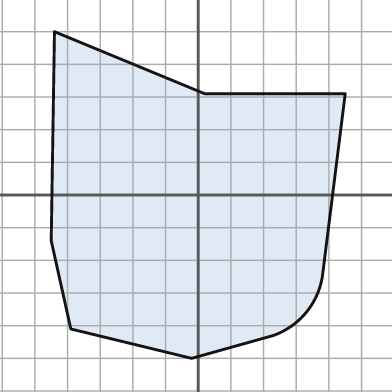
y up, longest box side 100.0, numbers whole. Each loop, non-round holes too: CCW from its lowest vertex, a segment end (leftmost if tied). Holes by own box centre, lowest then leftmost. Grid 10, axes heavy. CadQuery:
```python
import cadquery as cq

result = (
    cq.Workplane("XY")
    .moveTo(-2.0, -50.0)
    .lineTo(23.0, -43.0)
    .threePointArc((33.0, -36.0), (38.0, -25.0))
    .lineTo(45.0, 31.0)
    .lineTo(2.0, 31.0)
    .lineTo(-44.0, 50.0)
    .lineTo(-45.0, -14.0)
    .lineTo(-39.0, -41.0)
    .close()
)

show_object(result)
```